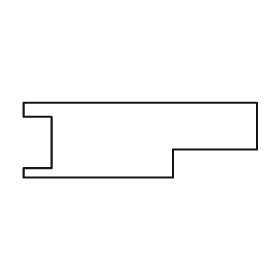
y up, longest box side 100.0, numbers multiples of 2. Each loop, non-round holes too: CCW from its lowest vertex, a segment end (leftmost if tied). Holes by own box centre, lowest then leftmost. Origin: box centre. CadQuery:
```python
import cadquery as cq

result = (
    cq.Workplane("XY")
    .moveTo(-50.0, -16.0)
    .lineTo(14.0, -16.0)
    .lineTo(14.0, -4.0)
    .lineTo(50.0, -4.0)
    .lineTo(50.0, 16.0)
    .lineTo(-50.0, 16.0)
    .lineTo(-50.0, 10.0)
    .lineTo(-38.0, 10.0)
    .lineTo(-38.0, -12.0)
    .lineTo(-50.0, -12.0)
    .close()
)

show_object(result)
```